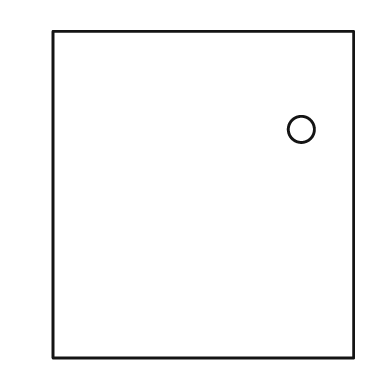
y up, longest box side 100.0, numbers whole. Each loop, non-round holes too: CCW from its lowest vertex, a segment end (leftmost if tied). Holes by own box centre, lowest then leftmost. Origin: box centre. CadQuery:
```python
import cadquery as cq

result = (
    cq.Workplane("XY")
    .moveTo(-46.0, -50.0)
    .lineTo(46.0, -50.0)
    .lineTo(46.0, 50.0)
    .lineTo(-46.0, 50.0)
    .close()
    .moveTo(30.0, 20.0)
    .circle(4.0)
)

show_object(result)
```